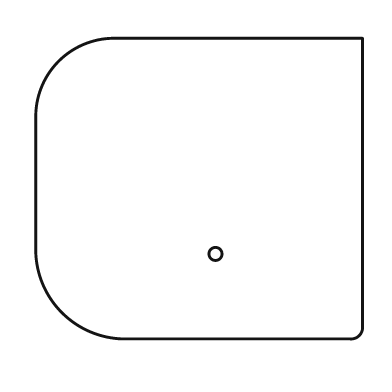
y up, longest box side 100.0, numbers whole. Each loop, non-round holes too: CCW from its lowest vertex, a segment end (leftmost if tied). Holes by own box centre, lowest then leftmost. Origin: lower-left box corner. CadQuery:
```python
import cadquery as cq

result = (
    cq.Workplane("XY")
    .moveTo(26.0, 0.0)
    .lineTo(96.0, 0.0)
    .threePointArc((99.0, 1.0), (100.0, 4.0))
    .lineTo(100.0, 92.0)
    .lineTo(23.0, 92.0)
    .threePointArc((7.0, 85.0), (0.0, 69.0))
    .lineTo(0.0, 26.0)
    .threePointArc((8.0, 8.0), (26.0, 0.0))
    .close()
    .moveTo(55.0, 26.0)
    .circle(2.0)
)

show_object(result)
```